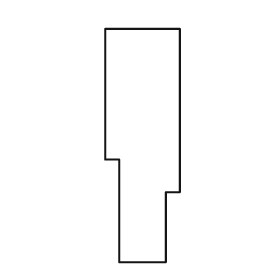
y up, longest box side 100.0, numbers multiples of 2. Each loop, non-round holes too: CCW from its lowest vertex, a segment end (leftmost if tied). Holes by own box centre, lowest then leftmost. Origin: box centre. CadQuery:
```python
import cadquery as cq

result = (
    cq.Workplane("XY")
    .moveTo(-10.0, -50.0)
    .lineTo(10.0, -50.0)
    .lineTo(10.0, -20.0)
    .lineTo(16.0, -20.0)
    .lineTo(16.0, 50.0)
    .lineTo(-16.0, 50.0)
    .lineTo(-16.0, -6.0)
    .lineTo(-10.0, -6.0)
    .close()
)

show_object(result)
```